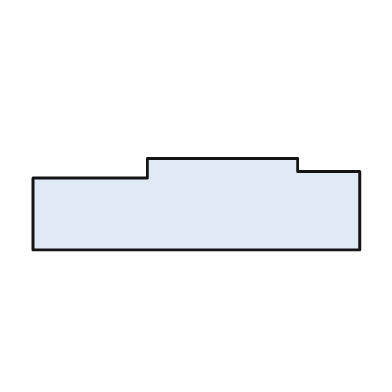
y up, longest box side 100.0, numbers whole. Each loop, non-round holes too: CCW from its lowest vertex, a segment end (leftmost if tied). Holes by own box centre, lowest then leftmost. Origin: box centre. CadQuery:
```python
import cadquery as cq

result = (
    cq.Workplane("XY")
    .moveTo(-50.0, -14.0)
    .lineTo(50.0, -14.0)
    .lineTo(50.0, 10.0)
    .lineTo(31.0, 10.0)
    .lineTo(31.0, 14.0)
    .lineTo(-15.0, 14.0)
    .lineTo(-15.0, 8.0)
    .lineTo(-50.0, 8.0)
    .close()
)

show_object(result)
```